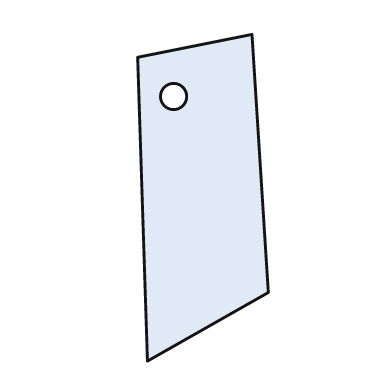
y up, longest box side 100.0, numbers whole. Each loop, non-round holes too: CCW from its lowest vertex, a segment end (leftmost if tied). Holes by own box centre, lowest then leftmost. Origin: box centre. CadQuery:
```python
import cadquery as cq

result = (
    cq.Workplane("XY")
    .moveTo(-17.0, -50.0)
    .lineTo(20.0, -29.0)
    .lineTo(15.0, 50.0)
    .lineTo(-20.0, 43.0)
    .close()
    .moveTo(-9.0, 31.0)
    .circle(4.0)
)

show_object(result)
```